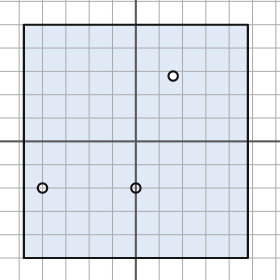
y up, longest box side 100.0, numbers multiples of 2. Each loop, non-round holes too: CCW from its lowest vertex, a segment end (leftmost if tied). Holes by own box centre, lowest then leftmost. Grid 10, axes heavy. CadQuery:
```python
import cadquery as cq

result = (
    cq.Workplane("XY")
    .moveTo(-48.0, -50.0)
    .lineTo(48.0, -50.0)
    .lineTo(48.0, 50.0)
    .lineTo(-48.0, 50.0)
    .close()
    .moveTo(-40.0, -20.0)
    .circle(2.0)
    .moveTo(0.0, -20.0)
    .circle(2.0)
    .moveTo(16.0, 28.0)
    .circle(2.0)
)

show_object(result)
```